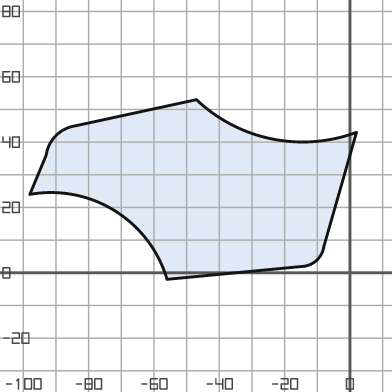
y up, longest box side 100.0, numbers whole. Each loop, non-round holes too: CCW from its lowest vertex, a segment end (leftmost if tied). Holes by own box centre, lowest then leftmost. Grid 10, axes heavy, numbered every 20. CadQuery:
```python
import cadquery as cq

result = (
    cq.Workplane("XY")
    .moveTo(-56.0, -2.0)
    .lineTo(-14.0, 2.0)
    .threePointArc((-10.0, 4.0), (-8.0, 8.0))
    .lineTo(2.0, 43.0)
    .threePointArc((-24.0, 41.0), (-47.0, 53.0))
    .lineTo(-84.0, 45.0)
    .threePointArc((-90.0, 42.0), (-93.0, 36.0))
    .lineTo(-98.0, 24.0)
    .threePointArc((-72.0, 19.0), (-56.0, -2.0))
    .close()
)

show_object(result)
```